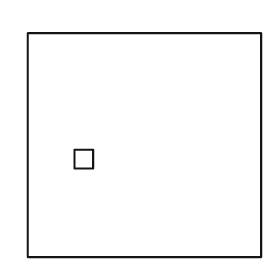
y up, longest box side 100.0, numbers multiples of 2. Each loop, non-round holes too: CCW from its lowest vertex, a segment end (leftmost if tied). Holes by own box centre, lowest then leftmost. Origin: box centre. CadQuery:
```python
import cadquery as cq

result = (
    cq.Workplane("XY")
    .moveTo(-50.0, -48.0)
    .lineTo(50.0, -48.0)
    .lineTo(50.0, 48.0)
    .lineTo(-50.0, 48.0)
    .close()
    .moveTo(-30.0, -10.0)
    .lineTo(-22.0, -10.0)
    .lineTo(-22.0, -2.0)
    .lineTo(-30.0, -2.0)
    .close()
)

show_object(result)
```